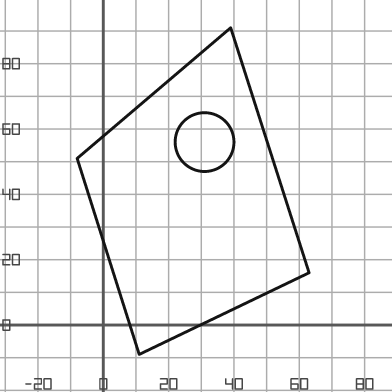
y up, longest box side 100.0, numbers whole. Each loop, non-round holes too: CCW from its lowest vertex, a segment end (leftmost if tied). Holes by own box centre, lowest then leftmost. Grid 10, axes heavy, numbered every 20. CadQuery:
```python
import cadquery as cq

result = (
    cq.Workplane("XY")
    .moveTo(11.0, -9.0)
    .lineTo(63.0, 16.0)
    .lineTo(39.0, 91.0)
    .lineTo(-8.0, 51.0)
    .close()
    .moveTo(31.0, 56.0)
    .circle(9.0)
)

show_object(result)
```